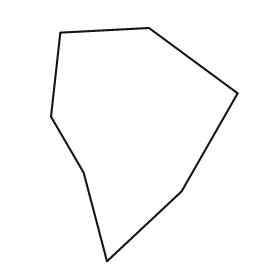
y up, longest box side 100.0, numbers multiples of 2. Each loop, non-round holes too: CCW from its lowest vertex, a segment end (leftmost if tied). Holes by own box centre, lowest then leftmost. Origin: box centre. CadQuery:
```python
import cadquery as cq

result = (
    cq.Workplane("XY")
    .moveTo(-16.0, -50.0)
    .lineTo(16.0, -20.0)
    .lineTo(40.0, 22.0)
    .lineTo(2.0, 50.0)
    .lineTo(-36.0, 48.0)
    .lineTo(-40.0, 12.0)
    .lineTo(-26.0, -12.0)
    .close()
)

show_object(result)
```